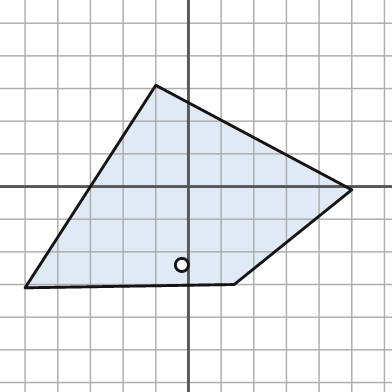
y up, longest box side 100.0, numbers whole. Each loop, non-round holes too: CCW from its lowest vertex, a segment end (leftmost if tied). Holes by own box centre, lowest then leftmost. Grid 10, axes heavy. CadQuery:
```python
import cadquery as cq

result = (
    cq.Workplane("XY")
    .moveTo(-50.0, -31.0)
    .lineTo(14.0, -30.0)
    .lineTo(50.0, -1.0)
    .lineTo(-10.0, 31.0)
    .close()
    .moveTo(-2.0, -24.0)
    .circle(2.0)
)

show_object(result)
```